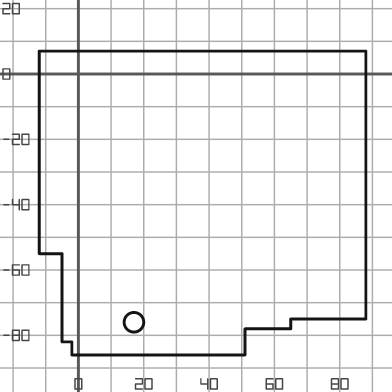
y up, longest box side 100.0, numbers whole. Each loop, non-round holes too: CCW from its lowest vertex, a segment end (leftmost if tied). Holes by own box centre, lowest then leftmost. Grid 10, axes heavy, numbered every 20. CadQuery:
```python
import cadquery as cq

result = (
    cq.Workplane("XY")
    .moveTo(-2.0, -86.0)
    .lineTo(51.0, -86.0)
    .lineTo(51.0, -78.0)
    .lineTo(65.0, -78.0)
    .lineTo(65.0, -75.0)
    .lineTo(88.0, -75.0)
    .lineTo(88.0, 7.0)
    .lineTo(-12.0, 7.0)
    .lineTo(-12.0, -55.0)
    .lineTo(-5.0, -55.0)
    .lineTo(-5.0, -82.0)
    .lineTo(-2.0, -82.0)
    .close()
    .moveTo(17.0, -76.0)
    .circle(3.0)
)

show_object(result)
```